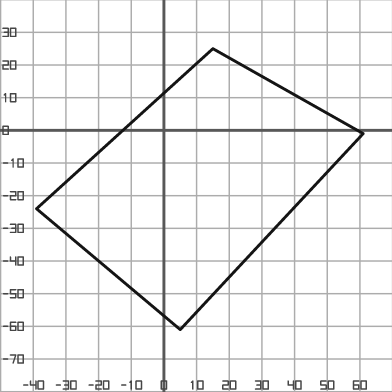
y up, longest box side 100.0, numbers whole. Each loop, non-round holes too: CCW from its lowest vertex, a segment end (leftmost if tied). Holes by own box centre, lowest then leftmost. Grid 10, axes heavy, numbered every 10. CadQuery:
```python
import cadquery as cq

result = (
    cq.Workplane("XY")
    .moveTo(5.0, -61.0)
    .lineTo(61.0, -1.0)
    .lineTo(15.0, 25.0)
    .lineTo(-39.0, -24.0)
    .close()
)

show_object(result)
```